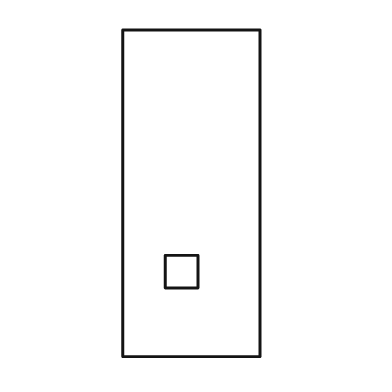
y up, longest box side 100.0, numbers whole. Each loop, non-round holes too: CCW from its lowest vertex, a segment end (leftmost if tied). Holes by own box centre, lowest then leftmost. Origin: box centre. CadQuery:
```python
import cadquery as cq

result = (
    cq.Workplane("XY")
    .moveTo(-21.0, -50.0)
    .lineTo(21.0, -50.0)
    .lineTo(21.0, 50.0)
    .lineTo(-21.0, 50.0)
    .close()
    .moveTo(-8.0, -29.0)
    .lineTo(2.0, -29.0)
    .lineTo(2.0, -19.0)
    .lineTo(-8.0, -19.0)
    .close()
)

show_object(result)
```